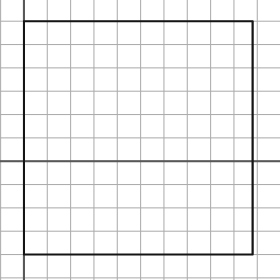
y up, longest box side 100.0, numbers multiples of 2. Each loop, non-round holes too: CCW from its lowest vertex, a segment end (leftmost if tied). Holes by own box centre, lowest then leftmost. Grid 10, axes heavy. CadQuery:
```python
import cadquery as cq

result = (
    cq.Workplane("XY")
    .moveTo(0.0, -40.0)
    .lineTo(98.0, -40.0)
    .lineTo(98.0, 60.0)
    .lineTo(0.0, 60.0)
    .close()
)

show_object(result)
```